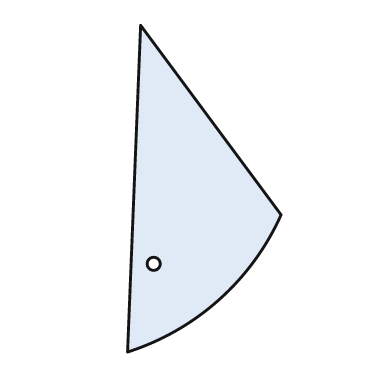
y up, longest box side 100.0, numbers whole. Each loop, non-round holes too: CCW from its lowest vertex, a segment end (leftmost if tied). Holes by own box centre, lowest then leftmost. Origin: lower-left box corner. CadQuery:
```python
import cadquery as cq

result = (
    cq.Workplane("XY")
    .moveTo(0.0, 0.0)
    .threePointArc((28.0, 16.0), (47.0, 42.0))
    .lineTo(4.0, 100.0)
    .close()
    .moveTo(8.0, 27.0)
    .circle(2.0)
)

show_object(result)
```